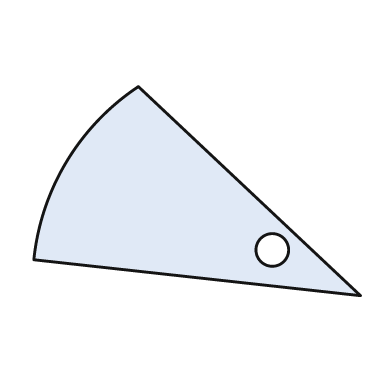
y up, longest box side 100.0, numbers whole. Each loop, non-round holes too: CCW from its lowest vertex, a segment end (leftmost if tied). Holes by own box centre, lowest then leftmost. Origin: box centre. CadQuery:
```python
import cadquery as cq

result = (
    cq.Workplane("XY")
    .moveTo(50.0, -32.0)
    .lineTo(-18.0, 32.0)
    .threePointArc((-40.0, 9.0), (-50.0, -21.0))
    .close()
    .moveTo(23.0, -18.0)
    .circle(5.0)
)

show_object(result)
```